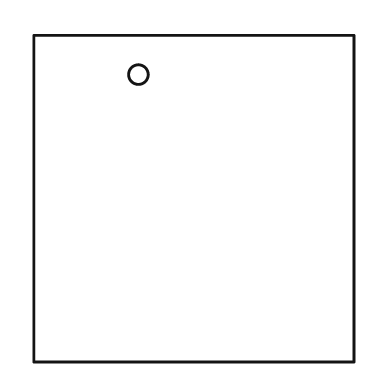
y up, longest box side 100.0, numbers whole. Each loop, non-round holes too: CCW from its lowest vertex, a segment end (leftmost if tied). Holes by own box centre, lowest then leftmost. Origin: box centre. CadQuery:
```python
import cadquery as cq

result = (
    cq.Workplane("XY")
    .moveTo(-49.0, -50.0)
    .lineTo(49.0, -50.0)
    .lineTo(49.0, 50.0)
    .lineTo(-49.0, 50.0)
    .close()
    .moveTo(-17.0, 38.0)
    .circle(3.0)
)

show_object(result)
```